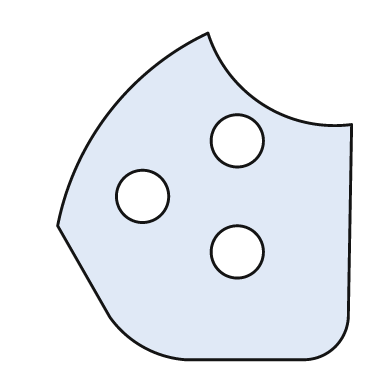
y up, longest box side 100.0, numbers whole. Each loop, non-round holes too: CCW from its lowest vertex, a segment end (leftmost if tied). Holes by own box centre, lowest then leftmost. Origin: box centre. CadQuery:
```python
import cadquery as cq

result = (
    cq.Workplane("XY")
    .moveTo(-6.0, -50.0)
    .lineTo(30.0, -50.0)
    .threePointArc((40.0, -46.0), (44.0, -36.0))
    .lineTo(45.0, 22.0)
    .threePointArc((18.0, 28.0), (1.0, 50.0))
    .threePointArc((-29.0, 26.0), (-45.0, -9.0))
    .lineTo(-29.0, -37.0)
    .threePointArc((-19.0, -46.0), (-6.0, -50.0))
    .close()
    .moveTo(10.0, -17.0)
    .circle(8.0)
    .moveTo(-19.0, 0.0)
    .circle(8.0)
    .moveTo(10.0, 17.0)
    .circle(8.0)
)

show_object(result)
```